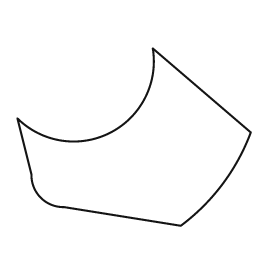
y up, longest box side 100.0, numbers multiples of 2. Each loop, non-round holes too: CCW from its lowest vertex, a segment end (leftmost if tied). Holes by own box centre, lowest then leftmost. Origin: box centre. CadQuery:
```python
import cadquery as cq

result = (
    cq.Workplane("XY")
    .moveTo(20.0, -38.0)
    .threePointArc((38.0, -20.0), (50.0, 2.0))
    .lineTo(8.0, 38.0)
    .threePointArc((-10.0, 2.0), (-50.0, 8.0))
    .lineTo(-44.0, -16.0)
    .threePointArc((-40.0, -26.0), (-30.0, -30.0))
    .close()
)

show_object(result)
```